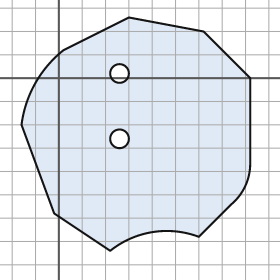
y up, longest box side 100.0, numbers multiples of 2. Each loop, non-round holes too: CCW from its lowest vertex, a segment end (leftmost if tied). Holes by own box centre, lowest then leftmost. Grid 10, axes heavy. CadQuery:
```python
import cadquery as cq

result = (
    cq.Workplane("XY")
    .moveTo(22.0, -74.0)
    .threePointArc((40.0, -66.0), (60.0, -68.0))
    .lineTo(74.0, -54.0)
    .threePointArc((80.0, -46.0), (82.0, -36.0))
    .lineTo(82.0, 0.0)
    .lineTo(62.0, 20.0)
    .lineTo(30.0, 26.0)
    .lineTo(2.0, 12.0)
    .threePointArc((-10.0, -2.0), (-16.0, -20.0))
    .lineTo(-2.0, -58.0)
    .close()
    .moveTo(26.0, -26.0)
    .circle(4.0)
    .moveTo(26.0, 2.0)
    .circle(4.0)
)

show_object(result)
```